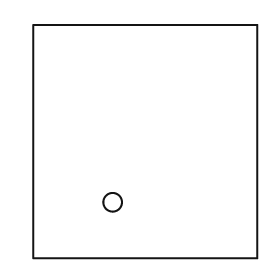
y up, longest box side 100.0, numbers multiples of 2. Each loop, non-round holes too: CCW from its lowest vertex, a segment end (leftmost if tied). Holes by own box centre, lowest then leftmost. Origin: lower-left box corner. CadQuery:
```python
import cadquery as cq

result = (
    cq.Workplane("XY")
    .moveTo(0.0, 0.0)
    .lineTo(96.0, 0.0)
    .lineTo(96.0, 100.0)
    .lineTo(0.0, 100.0)
    .close()
    .moveTo(34.0, 24.0)
    .circle(4.0)
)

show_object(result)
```